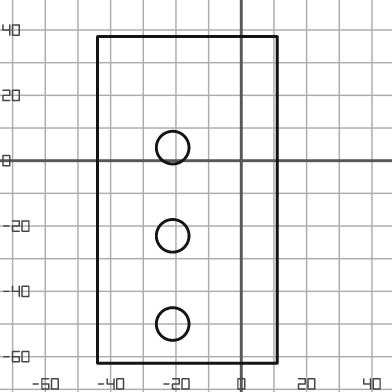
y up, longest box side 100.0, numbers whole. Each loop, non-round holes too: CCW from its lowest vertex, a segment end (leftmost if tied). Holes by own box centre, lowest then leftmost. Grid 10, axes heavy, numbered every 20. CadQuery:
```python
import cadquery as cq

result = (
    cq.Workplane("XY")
    .moveTo(-44.0, -62.0)
    .lineTo(11.0, -62.0)
    .lineTo(11.0, 38.0)
    .lineTo(-44.0, 38.0)
    .close()
    .moveTo(-21.0, -50.0)
    .circle(5.0)
    .moveTo(-21.0, -23.0)
    .circle(5.0)
    .moveTo(-21.0, 4.0)
    .circle(5.0)
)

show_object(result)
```